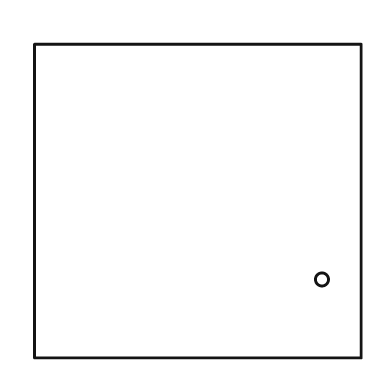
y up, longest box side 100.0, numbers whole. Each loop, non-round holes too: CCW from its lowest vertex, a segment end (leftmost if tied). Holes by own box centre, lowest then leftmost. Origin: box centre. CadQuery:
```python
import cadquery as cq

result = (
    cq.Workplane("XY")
    .moveTo(-50.0, -48.0)
    .lineTo(50.0, -48.0)
    .lineTo(50.0, 48.0)
    .lineTo(-50.0, 48.0)
    .close()
    .moveTo(38.0, -24.0)
    .circle(2.0)
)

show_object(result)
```